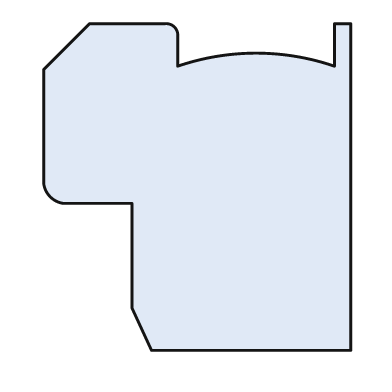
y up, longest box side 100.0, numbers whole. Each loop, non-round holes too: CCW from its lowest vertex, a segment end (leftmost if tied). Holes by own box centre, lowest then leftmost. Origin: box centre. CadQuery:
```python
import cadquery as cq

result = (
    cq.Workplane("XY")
    .moveTo(-14.0, -50.0)
    .lineTo(47.0, -50.0)
    .lineTo(47.0, 50.0)
    .lineTo(42.0, 50.0)
    .lineTo(42.0, 37.0)
    .threePointArc((18.0, 41.0), (-6.0, 37.0))
    .lineTo(-6.0, 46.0)
    .threePointArc((-7.0, 49.0), (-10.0, 50.0))
    .lineTo(-33.0, 50.0)
    .lineTo(-47.0, 36.0)
    .lineTo(-47.0, 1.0)
    .threePointArc((-45.0, -3.0), (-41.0, -5.0))
    .lineTo(-20.0, -5.0)
    .lineTo(-20.0, -37.0)
    .close()
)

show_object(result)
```